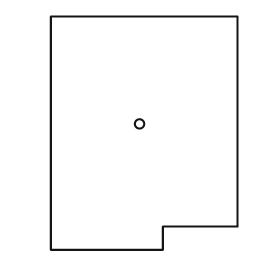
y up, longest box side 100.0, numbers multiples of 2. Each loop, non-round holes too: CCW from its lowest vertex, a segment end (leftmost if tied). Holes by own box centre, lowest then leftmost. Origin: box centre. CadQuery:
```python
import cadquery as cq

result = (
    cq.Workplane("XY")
    .moveTo(-40.0, -50.0)
    .lineTo(8.0, -50.0)
    .lineTo(8.0, -40.0)
    .lineTo(40.0, -40.0)
    .lineTo(40.0, 50.0)
    .lineTo(-40.0, 50.0)
    .close()
    .moveTo(-2.0, 4.0)
    .circle(2.0)
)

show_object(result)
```